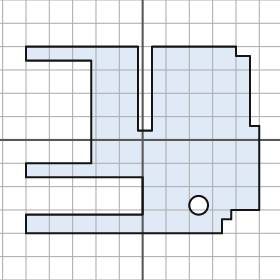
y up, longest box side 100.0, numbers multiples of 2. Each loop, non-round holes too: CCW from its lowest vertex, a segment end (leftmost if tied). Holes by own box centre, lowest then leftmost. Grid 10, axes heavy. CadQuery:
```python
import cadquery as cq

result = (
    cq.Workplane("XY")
    .moveTo(-50.0, -40.0)
    .lineTo(34.0, -40.0)
    .lineTo(34.0, -34.0)
    .lineTo(38.0, -34.0)
    .lineTo(38.0, -30.0)
    .lineTo(50.0, -30.0)
    .lineTo(50.0, 6.0)
    .lineTo(46.0, 6.0)
    .lineTo(46.0, 36.0)
    .lineTo(40.0, 36.0)
    .lineTo(40.0, 40.0)
    .lineTo(4.0, 40.0)
    .lineTo(4.0, 4.0)
    .lineTo(-2.0, 4.0)
    .lineTo(-2.0, 40.0)
    .lineTo(-50.0, 40.0)
    .lineTo(-50.0, 34.0)
    .lineTo(-22.0, 34.0)
    .lineTo(-22.0, -10.0)
    .lineTo(-50.0, -10.0)
    .lineTo(-50.0, -16.0)
    .lineTo(0.0, -16.0)
    .lineTo(0.0, -32.0)
    .lineTo(-50.0, -32.0)
    .close()
    .moveTo(24.0, -28.0)
    .circle(4.0)
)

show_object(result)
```